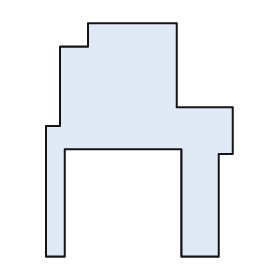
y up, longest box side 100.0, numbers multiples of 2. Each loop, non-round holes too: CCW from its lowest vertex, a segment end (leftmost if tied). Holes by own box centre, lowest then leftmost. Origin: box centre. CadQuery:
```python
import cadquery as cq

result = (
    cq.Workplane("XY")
    .moveTo(-40.0, -50.0)
    .lineTo(-32.0, -50.0)
    .lineTo(-32.0, -4.0)
    .lineTo(18.0, -4.0)
    .lineTo(18.0, -50.0)
    .lineTo(34.0, -50.0)
    .lineTo(34.0, -6.0)
    .lineTo(40.0, -6.0)
    .lineTo(40.0, 14.0)
    .lineTo(16.0, 14.0)
    .lineTo(16.0, 50.0)
    .lineTo(-22.0, 50.0)
    .lineTo(-22.0, 40.0)
    .lineTo(-34.0, 40.0)
    .lineTo(-34.0, 6.0)
    .lineTo(-40.0, 6.0)
    .close()
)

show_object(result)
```